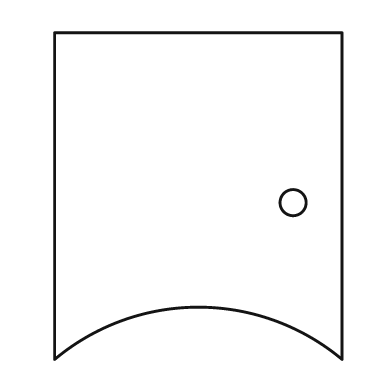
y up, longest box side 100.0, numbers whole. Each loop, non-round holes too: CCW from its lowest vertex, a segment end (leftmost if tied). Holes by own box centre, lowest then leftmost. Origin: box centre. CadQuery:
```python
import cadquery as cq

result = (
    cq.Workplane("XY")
    .moveTo(-44.0, -50.0)
    .threePointArc((0.0, -34.0), (44.0, -50.0))
    .lineTo(44.0, 50.0)
    .lineTo(-44.0, 50.0)
    .close()
    .moveTo(29.0, -2.0)
    .circle(4.0)
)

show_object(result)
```